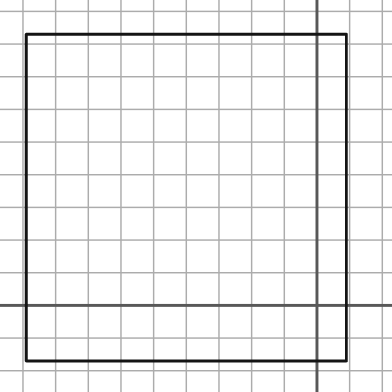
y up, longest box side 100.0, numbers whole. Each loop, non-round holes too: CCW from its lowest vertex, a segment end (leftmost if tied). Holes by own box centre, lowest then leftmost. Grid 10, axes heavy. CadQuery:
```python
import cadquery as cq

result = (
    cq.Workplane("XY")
    .moveTo(-89.0, -17.0)
    .lineTo(9.0, -17.0)
    .lineTo(9.0, 83.0)
    .lineTo(-89.0, 83.0)
    .close()
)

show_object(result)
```